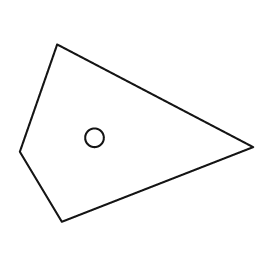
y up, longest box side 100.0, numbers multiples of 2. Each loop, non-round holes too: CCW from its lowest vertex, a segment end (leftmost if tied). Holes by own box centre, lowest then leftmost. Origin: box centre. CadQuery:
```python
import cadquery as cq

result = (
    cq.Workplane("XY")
    .moveTo(-32.0, -38.0)
    .lineTo(50.0, -6.0)
    .lineTo(-34.0, 38.0)
    .lineTo(-50.0, -8.0)
    .close()
    .moveTo(-18.0, -2.0)
    .circle(4.0)
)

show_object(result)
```